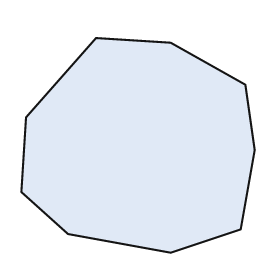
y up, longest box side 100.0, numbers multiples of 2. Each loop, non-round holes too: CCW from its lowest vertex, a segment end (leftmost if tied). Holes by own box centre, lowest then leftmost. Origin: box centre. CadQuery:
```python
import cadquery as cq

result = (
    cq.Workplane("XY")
    .moveTo(14.0, -46.0)
    .lineTo(44.0, -36.0)
    .lineTo(50.0, -2.0)
    .lineTo(46.0, 26.0)
    .lineTo(14.0, 44.0)
    .lineTo(-18.0, 46.0)
    .lineTo(-48.0, 12.0)
    .lineTo(-50.0, -20.0)
    .lineTo(-30.0, -38.0)
    .close()
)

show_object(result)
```